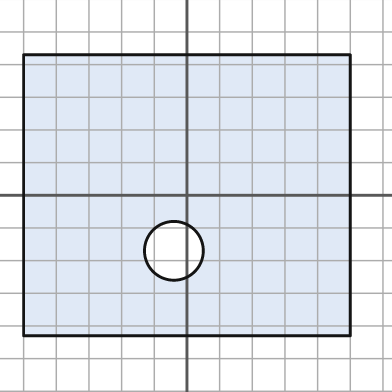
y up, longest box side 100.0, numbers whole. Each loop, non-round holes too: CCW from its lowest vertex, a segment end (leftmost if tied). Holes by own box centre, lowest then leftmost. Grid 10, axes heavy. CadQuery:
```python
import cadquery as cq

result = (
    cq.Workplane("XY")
    .moveTo(-50.0, -43.0)
    .lineTo(50.0, -43.0)
    .lineTo(50.0, 43.0)
    .lineTo(-50.0, 43.0)
    .close()
    .moveTo(-4.0, -17.0)
    .circle(9.0)
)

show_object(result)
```